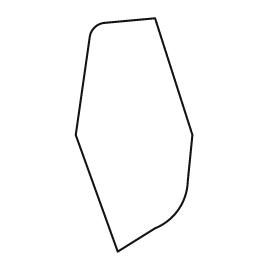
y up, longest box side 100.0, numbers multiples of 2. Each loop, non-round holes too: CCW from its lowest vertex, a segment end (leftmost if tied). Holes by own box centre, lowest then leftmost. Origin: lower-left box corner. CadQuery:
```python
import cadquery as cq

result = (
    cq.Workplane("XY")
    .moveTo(18.0, 0.0)
    .lineTo(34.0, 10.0)
    .threePointArc((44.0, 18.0), (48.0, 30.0))
    .lineTo(50.0, 50.0)
    .lineTo(34.0, 100.0)
    .lineTo(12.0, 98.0)
    .threePointArc((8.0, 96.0), (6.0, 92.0))
    .lineTo(0.0, 50.0)
    .close()
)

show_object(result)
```